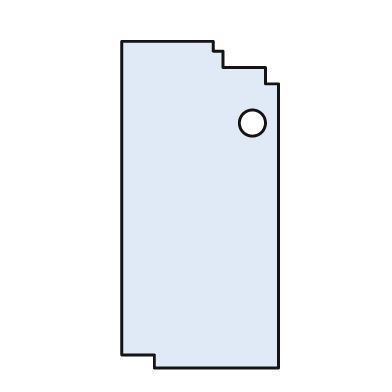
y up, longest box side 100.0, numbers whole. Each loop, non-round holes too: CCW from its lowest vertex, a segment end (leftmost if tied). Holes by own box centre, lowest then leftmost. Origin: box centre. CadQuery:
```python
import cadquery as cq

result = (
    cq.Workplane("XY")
    .moveTo(-14.0, -50.0)
    .lineTo(24.0, -50.0)
    .lineTo(24.0, 37.0)
    .lineTo(20.0, 37.0)
    .lineTo(20.0, 42.0)
    .lineTo(7.0, 42.0)
    .lineTo(7.0, 47.0)
    .lineTo(4.0, 47.0)
    .lineTo(4.0, 50.0)
    .lineTo(-24.0, 50.0)
    .lineTo(-24.0, -46.0)
    .lineTo(-14.0, -46.0)
    .close()
    .moveTo(16.0, 25.0)
    .circle(4.0)
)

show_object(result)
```